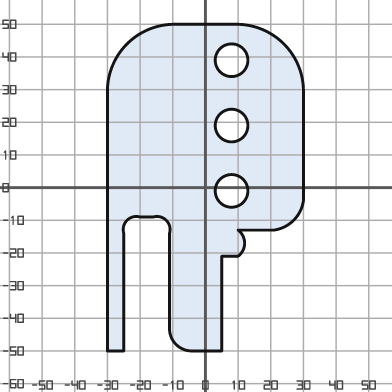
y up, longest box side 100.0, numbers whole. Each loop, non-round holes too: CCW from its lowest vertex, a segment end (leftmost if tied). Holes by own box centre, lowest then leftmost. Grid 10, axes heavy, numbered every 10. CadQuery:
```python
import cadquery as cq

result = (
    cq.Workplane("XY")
    .moveTo(-30.0, -50.0)
    .lineTo(-25.0, -50.0)
    .lineTo(-25.0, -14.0)
    .threePointArc((-24.0, -10.0), (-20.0, -9.0))
    .lineTo(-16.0, -9.0)
    .threePointArc((-12.0, -10.0), (-11.0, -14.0))
    .lineTo(-11.0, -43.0)
    .threePointArc((-9.0, -48.0), (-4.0, -50.0))
    .lineTo(5.0, -50.0)
    .lineTo(5.0, -21.0)
    .lineTo(10.0, -21.0)
    .threePointArc((12.0, -17.0), (10.0, -13.0))
    .lineTo(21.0, -13.0)
    .threePointArc((27.0, -10.0), (30.0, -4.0))
    .lineTo(30.0, 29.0)
    .threePointArc((24.0, 44.0), (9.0, 50.0))
    .lineTo(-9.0, 50.0)
    .threePointArc((-24.0, 44.0), (-30.0, 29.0))
    .close()
    .moveTo(8.0, -1.0)
    .circle(5.0)
    .moveTo(8.0, 19.0)
    .circle(5.0)
    .moveTo(8.0, 39.0)
    .circle(5.0)
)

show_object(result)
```